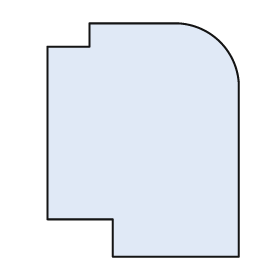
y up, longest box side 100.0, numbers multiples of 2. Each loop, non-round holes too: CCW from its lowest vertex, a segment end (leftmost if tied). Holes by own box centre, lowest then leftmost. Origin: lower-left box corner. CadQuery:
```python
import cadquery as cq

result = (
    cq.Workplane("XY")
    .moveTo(28.0, 0.0)
    .lineTo(82.0, 0.0)
    .lineTo(82.0, 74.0)
    .threePointArc((74.0, 92.0), (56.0, 100.0))
    .lineTo(18.0, 100.0)
    .lineTo(18.0, 90.0)
    .lineTo(0.0, 90.0)
    .lineTo(0.0, 16.0)
    .lineTo(28.0, 16.0)
    .close()
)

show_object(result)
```